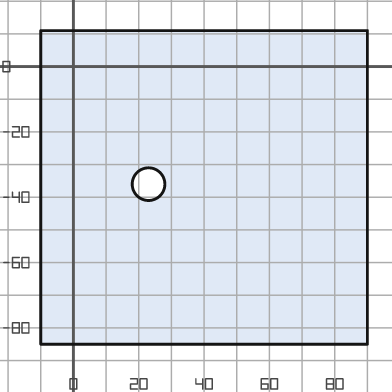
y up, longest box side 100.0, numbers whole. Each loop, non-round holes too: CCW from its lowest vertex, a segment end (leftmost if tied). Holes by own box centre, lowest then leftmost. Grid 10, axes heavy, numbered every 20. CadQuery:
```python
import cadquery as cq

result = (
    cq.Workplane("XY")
    .moveTo(-10.0, -85.0)
    .lineTo(90.0, -85.0)
    .lineTo(90.0, 11.0)
    .lineTo(-10.0, 11.0)
    .close()
    .moveTo(23.0, -36.0)
    .circle(5.0)
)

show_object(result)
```